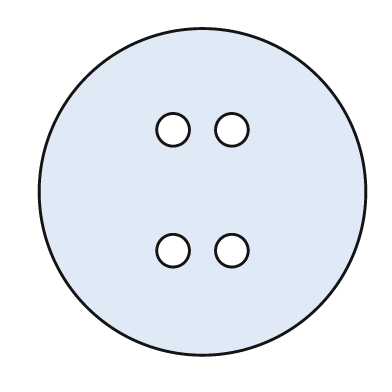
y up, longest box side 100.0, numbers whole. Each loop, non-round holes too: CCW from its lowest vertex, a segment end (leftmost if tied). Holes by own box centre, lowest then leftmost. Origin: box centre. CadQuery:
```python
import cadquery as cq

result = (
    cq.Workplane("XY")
    .moveTo(0.0, 0.0)
    .circle(50.0)
    .moveTo(-9.0, -18.0)
    .circle(5.0)
    .moveTo(9.0, -18.0)
    .circle(5.0)
    .moveTo(-9.0, 19.0)
    .circle(5.0)
    .moveTo(9.0, 19.0)
    .circle(5.0)
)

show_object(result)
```